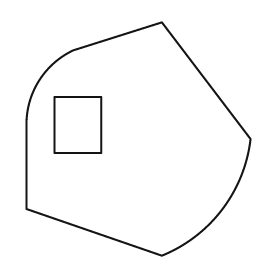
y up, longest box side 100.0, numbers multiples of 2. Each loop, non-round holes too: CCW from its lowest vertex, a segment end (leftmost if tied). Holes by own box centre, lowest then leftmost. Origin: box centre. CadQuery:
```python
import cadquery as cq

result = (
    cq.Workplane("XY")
    .moveTo(10.0, -50.0)
    .threePointArc((36.0, -30.0), (48.0, 0.0))
    .lineTo(10.0, 50.0)
    .lineTo(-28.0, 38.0)
    .threePointArc((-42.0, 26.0), (-48.0, 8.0))
    .lineTo(-48.0, -30.0)
    .close()
    .moveTo(-36.0, -6.0)
    .lineTo(-16.0, -6.0)
    .lineTo(-16.0, 18.0)
    .lineTo(-36.0, 18.0)
    .close()
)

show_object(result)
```